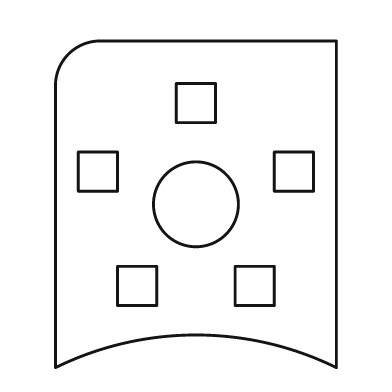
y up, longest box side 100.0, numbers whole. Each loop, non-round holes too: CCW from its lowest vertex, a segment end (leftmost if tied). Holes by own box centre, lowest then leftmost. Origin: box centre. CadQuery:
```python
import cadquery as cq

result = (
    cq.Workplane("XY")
    .moveTo(-43.0, -50.0)
    .threePointArc((0.0, -40.0), (43.0, -50.0))
    .lineTo(43.0, 50.0)
    .lineTo(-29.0, 50.0)
    .threePointArc((-39.0, 46.0), (-43.0, 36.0))
    .close()
    .moveTo(-24.0, -31.0)
    .lineTo(-12.0, -31.0)
    .lineTo(-12.0, -19.0)
    .lineTo(-24.0, -19.0)
    .close()
    .moveTo(12.0, -31.0)
    .lineTo(24.0, -31.0)
    .lineTo(24.0, -19.0)
    .lineTo(12.0, -19.0)
    .close()
    .moveTo(0.0, 0.0)
    .circle(13.0)
    .moveTo(-36.0, 4.0)
    .lineTo(-24.0, 4.0)
    .lineTo(-24.0, 16.0)
    .lineTo(-36.0, 16.0)
    .close()
    .moveTo(24.0, 4.0)
    .lineTo(36.0, 4.0)
    .lineTo(36.0, 16.0)
    .lineTo(24.0, 16.0)
    .close()
    .moveTo(-6.0, 25.0)
    .lineTo(6.0, 25.0)
    .lineTo(6.0, 37.0)
    .lineTo(-6.0, 37.0)
    .close()
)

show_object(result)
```